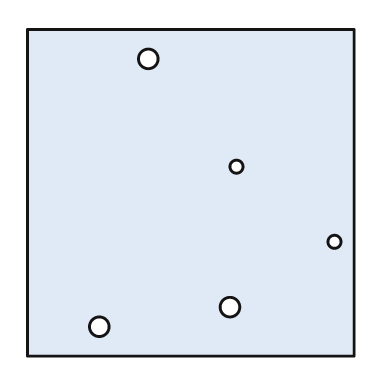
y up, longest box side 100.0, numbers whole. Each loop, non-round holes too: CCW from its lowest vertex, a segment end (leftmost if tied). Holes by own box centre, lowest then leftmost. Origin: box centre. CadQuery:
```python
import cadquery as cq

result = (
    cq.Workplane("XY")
    .moveTo(-50.0, -50.0)
    .lineTo(50.0, -50.0)
    .lineTo(50.0, 50.0)
    .lineTo(-50.0, 50.0)
    .close()
    .moveTo(-28.0, -41.0)
    .circle(3.0)
    .moveTo(12.0, -35.0)
    .circle(3.0)
    .moveTo(44.0, -15.0)
    .circle(2.0)
    .moveTo(14.0, 8.0)
    .circle(2.0)
    .moveTo(-13.0, 41.0)
    .circle(3.0)
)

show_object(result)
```